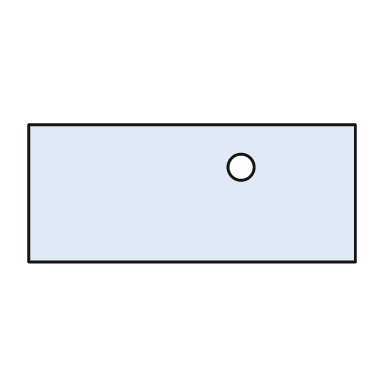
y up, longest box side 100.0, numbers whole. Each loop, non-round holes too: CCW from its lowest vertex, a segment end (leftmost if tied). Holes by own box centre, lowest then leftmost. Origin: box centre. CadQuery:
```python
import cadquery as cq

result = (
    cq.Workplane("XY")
    .moveTo(-50.0, -21.0)
    .lineTo(50.0, -21.0)
    .lineTo(50.0, 21.0)
    .lineTo(-50.0, 21.0)
    .close()
    .moveTo(15.0, 8.0)
    .circle(4.0)
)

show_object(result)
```